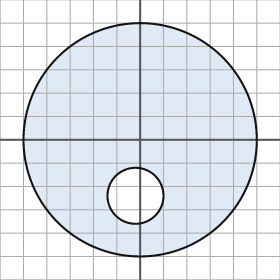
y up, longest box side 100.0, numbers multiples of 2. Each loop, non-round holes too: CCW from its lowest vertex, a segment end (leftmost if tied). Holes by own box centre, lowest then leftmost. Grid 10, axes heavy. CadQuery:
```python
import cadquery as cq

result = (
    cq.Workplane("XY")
    .moveTo(0.0, 0.0)
    .circle(50.0)
    .moveTo(-2.0, -24.0)
    .circle(12.0)
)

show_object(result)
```